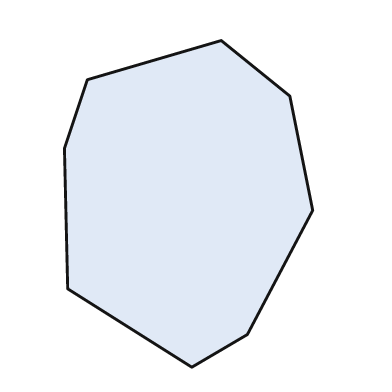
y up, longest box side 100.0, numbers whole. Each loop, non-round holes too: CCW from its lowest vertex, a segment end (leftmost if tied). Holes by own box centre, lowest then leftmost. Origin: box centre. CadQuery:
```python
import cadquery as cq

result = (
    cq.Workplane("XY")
    .moveTo(1.0, -50.0)
    .lineTo(18.0, -40.0)
    .lineTo(38.0, -2.0)
    .lineTo(31.0, 33.0)
    .lineTo(10.0, 50.0)
    .lineTo(-31.0, 38.0)
    .lineTo(-38.0, 17.0)
    .lineTo(-37.0, -26.0)
    .close()
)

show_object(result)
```